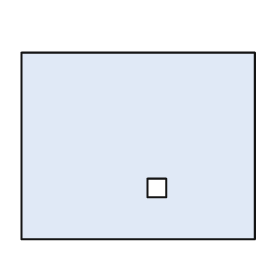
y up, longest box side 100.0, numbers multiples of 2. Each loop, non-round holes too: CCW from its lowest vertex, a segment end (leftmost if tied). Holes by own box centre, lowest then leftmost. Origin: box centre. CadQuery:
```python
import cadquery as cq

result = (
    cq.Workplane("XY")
    .moveTo(-50.0, -40.0)
    .lineTo(50.0, -40.0)
    .lineTo(50.0, 40.0)
    .lineTo(-50.0, 40.0)
    .close()
    .moveTo(4.0, -22.0)
    .lineTo(12.0, -22.0)
    .lineTo(12.0, -14.0)
    .lineTo(4.0, -14.0)
    .close()
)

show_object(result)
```